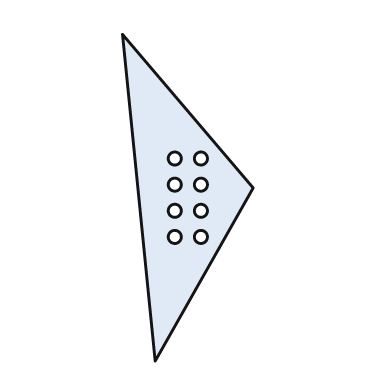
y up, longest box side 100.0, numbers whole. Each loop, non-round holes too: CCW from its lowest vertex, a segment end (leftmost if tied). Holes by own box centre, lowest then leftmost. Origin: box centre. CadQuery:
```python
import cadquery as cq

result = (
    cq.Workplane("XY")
    .moveTo(-10.0, -50.0)
    .lineTo(20.0, 3.0)
    .lineTo(-20.0, 50.0)
    .close()
    .moveTo(-4.0, -12.0)
    .circle(2.0)
    .moveTo(4.0, -12.0)
    .circle(2.0)
    .moveTo(-4.0, -4.0)
    .circle(2.0)
    .moveTo(4.0, -4.0)
    .circle(2.0)
    .moveTo(-4.0, 4.0)
    .circle(2.0)
    .moveTo(4.0, 4.0)
    .circle(2.0)
    .moveTo(-4.0, 12.0)
    .circle(2.0)
    .moveTo(4.0, 12.0)
    .circle(2.0)
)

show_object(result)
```